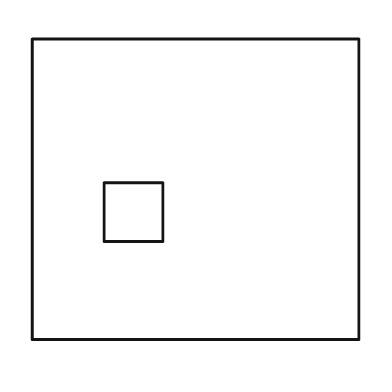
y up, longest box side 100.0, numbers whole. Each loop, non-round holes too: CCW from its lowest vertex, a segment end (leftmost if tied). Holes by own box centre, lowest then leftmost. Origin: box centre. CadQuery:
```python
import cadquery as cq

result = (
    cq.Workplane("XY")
    .moveTo(-50.0, -46.0)
    .lineTo(50.0, -46.0)
    .lineTo(50.0, 46.0)
    .lineTo(-50.0, 46.0)
    .close()
    .moveTo(-28.0, -16.0)
    .lineTo(-10.0, -16.0)
    .lineTo(-10.0, 2.0)
    .lineTo(-28.0, 2.0)
    .close()
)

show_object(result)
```